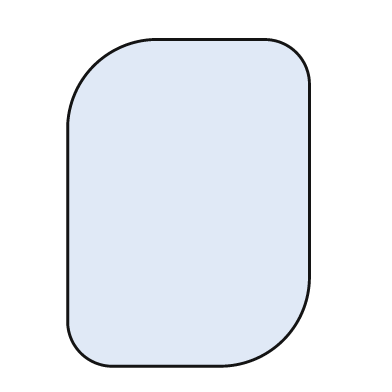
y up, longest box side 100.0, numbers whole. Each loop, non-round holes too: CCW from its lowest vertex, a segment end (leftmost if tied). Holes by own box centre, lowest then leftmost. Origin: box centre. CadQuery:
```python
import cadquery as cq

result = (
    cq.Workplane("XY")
    .moveTo(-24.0, -50.0)
    .lineTo(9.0, -50.0)
    .threePointArc((29.0, -42.0), (37.0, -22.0))
    .lineTo(37.0, 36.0)
    .threePointArc((33.0, 46.0), (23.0, 50.0))
    .lineTo(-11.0, 50.0)
    .threePointArc((-29.0, 42.0), (-37.0, 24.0))
    .lineTo(-37.0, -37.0)
    .threePointArc((-33.0, -46.0), (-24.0, -50.0))
    .close()
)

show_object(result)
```